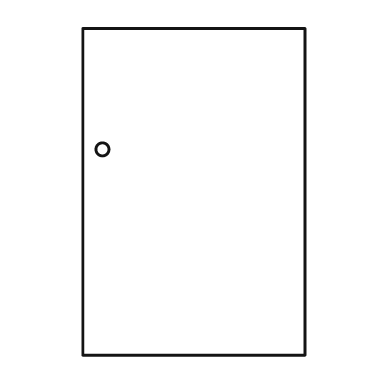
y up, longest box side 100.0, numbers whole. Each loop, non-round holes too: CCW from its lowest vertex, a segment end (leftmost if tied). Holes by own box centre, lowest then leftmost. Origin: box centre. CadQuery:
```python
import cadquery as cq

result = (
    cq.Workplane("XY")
    .moveTo(-34.0, -50.0)
    .lineTo(34.0, -50.0)
    .lineTo(34.0, 50.0)
    .lineTo(-34.0, 50.0)
    .close()
    .moveTo(-28.0, 13.0)
    .circle(2.0)
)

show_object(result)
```